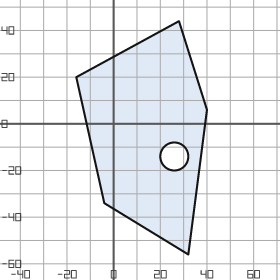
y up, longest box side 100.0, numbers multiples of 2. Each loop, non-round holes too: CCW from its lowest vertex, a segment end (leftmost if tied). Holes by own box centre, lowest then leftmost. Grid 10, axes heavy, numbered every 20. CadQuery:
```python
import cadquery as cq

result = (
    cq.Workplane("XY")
    .moveTo(32.0, -56.0)
    .lineTo(40.0, 6.0)
    .lineTo(28.0, 44.0)
    .lineTo(-16.0, 20.0)
    .lineTo(-4.0, -34.0)
    .close()
    .moveTo(26.0, -14.0)
    .circle(6.0)
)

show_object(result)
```